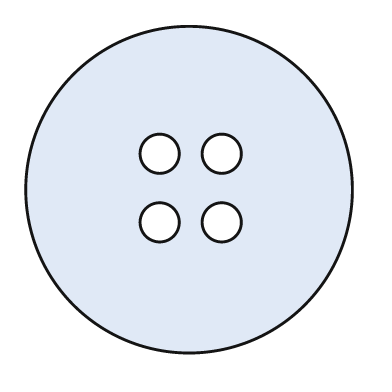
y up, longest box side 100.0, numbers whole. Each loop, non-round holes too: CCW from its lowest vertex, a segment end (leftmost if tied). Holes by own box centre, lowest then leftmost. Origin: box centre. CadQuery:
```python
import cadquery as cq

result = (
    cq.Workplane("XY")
    .moveTo(0.0, 0.0)
    .circle(50.0)
    .moveTo(-9.0, -10.0)
    .circle(6.0)
    .moveTo(10.0, -10.0)
    .circle(6.0)
    .moveTo(-9.0, 11.0)
    .circle(6.0)
    .moveTo(10.0, 11.0)
    .circle(6.0)
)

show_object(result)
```